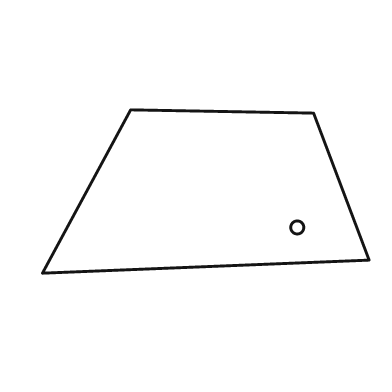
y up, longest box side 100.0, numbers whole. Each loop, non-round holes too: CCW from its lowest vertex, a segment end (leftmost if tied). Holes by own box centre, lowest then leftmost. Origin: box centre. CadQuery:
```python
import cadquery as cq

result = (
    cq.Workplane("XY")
    .moveTo(-50.0, -25.0)
    .lineTo(50.0, -21.0)
    .lineTo(33.0, 24.0)
    .lineTo(-23.0, 25.0)
    .close()
    .moveTo(28.0, -11.0)
    .circle(2.0)
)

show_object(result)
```